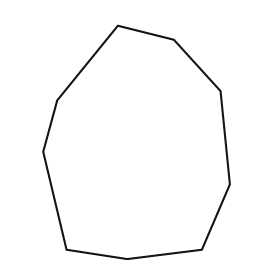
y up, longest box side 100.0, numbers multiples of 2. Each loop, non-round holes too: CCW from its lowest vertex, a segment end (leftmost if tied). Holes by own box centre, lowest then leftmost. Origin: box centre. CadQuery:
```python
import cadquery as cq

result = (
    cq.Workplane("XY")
    .moveTo(-4.0, -50.0)
    .lineTo(28.0, -46.0)
    .lineTo(40.0, -18.0)
    .lineTo(36.0, 22.0)
    .lineTo(16.0, 44.0)
    .lineTo(-8.0, 50.0)
    .lineTo(-34.0, 18.0)
    .lineTo(-40.0, -4.0)
    .lineTo(-30.0, -46.0)
    .close()
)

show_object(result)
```